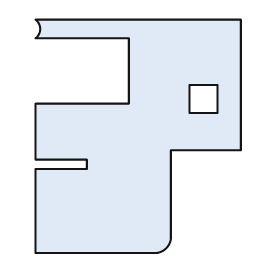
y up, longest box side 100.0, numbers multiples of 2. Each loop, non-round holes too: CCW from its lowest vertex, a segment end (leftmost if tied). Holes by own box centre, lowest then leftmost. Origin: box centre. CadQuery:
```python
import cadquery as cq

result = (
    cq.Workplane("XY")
    .moveTo(-44.0, -50.0)
    .lineTo(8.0, -50.0)
    .threePointArc((12.0, -48.0), (14.0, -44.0))
    .lineTo(14.0, -6.0)
    .lineTo(44.0, -6.0)
    .lineTo(44.0, 50.0)
    .lineTo(-44.0, 50.0)
    .threePointArc((-42.0, 46.0), (-44.0, 42.0))
    .lineTo(-4.0, 42.0)
    .lineTo(-4.0, 14.0)
    .lineTo(-44.0, 14.0)
    .lineTo(-44.0, -10.0)
    .lineTo(-22.0, -10.0)
    .lineTo(-22.0, -14.0)
    .lineTo(-44.0, -14.0)
    .close()
    .moveTo(22.0, 10.0)
    .lineTo(34.0, 10.0)
    .lineTo(34.0, 22.0)
    .lineTo(22.0, 22.0)
    .close()
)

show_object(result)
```